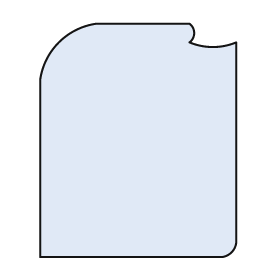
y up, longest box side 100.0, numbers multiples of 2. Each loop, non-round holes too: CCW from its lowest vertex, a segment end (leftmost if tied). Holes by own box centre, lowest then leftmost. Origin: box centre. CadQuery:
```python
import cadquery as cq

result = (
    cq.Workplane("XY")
    .moveTo(-42.0, -50.0)
    .lineTo(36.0, -50.0)
    .threePointArc((40.0, -48.0), (42.0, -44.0))
    .lineTo(42.0, 42.0)
    .threePointArc((32.0, 40.0), (22.0, 42.0))
    .threePointArc((24.0, 46.0), (22.0, 50.0))
    .lineTo(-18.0, 50.0)
    .threePointArc((-34.0, 42.0), (-42.0, 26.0))
    .close()
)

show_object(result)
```